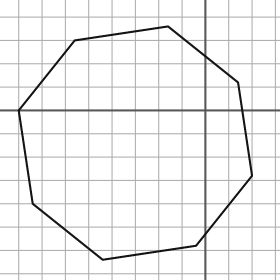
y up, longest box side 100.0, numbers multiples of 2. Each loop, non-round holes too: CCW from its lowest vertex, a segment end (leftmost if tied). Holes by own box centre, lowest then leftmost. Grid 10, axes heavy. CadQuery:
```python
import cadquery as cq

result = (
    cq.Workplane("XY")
    .moveTo(-44.0, -64.0)
    .lineTo(-4.0, -58.0)
    .lineTo(20.0, -28.0)
    .lineTo(14.0, 12.0)
    .lineTo(-16.0, 36.0)
    .lineTo(-56.0, 30.0)
    .lineTo(-80.0, 0.0)
    .lineTo(-74.0, -40.0)
    .close()
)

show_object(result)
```